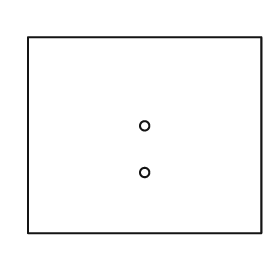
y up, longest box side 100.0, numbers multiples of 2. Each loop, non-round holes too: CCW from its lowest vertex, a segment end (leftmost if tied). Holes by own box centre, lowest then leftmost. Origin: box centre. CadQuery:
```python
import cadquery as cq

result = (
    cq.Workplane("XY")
    .moveTo(-50.0, -42.0)
    .lineTo(50.0, -42.0)
    .lineTo(50.0, 42.0)
    .lineTo(-50.0, 42.0)
    .close()
    .moveTo(0.0, -16.0)
    .circle(2.0)
    .moveTo(0.0, 4.0)
    .circle(2.0)
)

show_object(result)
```